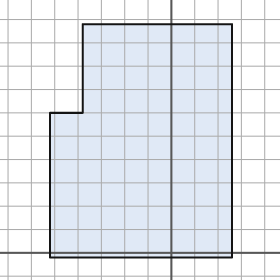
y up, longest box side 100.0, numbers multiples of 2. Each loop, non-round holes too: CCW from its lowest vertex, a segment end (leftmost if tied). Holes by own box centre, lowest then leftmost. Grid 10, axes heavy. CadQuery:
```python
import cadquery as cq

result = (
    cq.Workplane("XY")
    .moveTo(-52.0, -2.0)
    .lineTo(26.0, -2.0)
    .lineTo(26.0, 98.0)
    .lineTo(-38.0, 98.0)
    .lineTo(-38.0, 60.0)
    .lineTo(-52.0, 60.0)
    .close()
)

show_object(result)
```